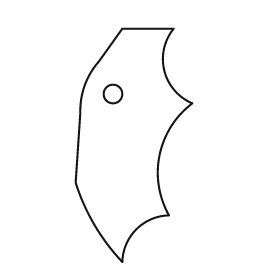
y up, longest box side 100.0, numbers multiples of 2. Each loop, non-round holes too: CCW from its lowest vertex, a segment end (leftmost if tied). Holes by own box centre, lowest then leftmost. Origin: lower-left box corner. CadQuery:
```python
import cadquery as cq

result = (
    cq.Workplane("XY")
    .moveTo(20.0, 0.0)
    .threePointArc((26.0, 14.0), (40.0, 20.0))
    .threePointArc((36.0, 46.0), (50.0, 68.0))
    .threePointArc((38.0, 82.0), (42.0, 100.0))
    .lineTo(20.0, 100.0)
    .lineTo(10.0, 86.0)
    .threePointArc((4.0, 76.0), (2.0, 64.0))
    .lineTo(0.0, 34.0)
    .threePointArc((8.0, 16.0), (20.0, 0.0))
    .close()
    .moveTo(16.0, 72.0)
    .circle(4.0)
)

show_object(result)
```